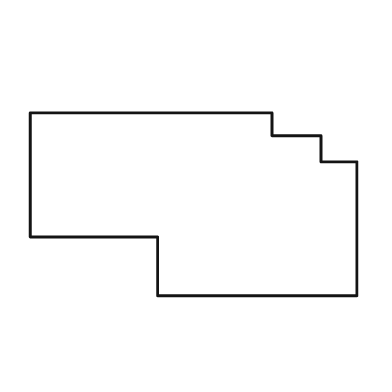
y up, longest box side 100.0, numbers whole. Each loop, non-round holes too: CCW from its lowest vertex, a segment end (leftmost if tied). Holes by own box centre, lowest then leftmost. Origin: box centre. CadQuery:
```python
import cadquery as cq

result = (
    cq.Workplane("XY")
    .moveTo(-11.0, -28.0)
    .lineTo(50.0, -28.0)
    .lineTo(50.0, 13.0)
    .lineTo(39.0, 13.0)
    .lineTo(39.0, 21.0)
    .lineTo(24.0, 21.0)
    .lineTo(24.0, 28.0)
    .lineTo(-50.0, 28.0)
    .lineTo(-50.0, -10.0)
    .lineTo(-11.0, -10.0)
    .close()
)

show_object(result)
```